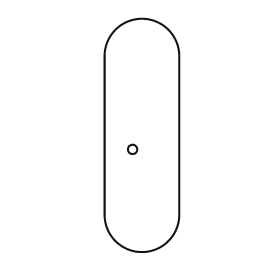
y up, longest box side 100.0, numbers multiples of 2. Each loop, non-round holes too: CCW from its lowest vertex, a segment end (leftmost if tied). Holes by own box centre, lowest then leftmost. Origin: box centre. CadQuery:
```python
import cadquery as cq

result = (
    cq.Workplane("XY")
    .moveTo(-16.0, -34.0)
    .threePointArc((0.0, -50.0), (16.0, -34.0))
    .lineTo(16.0, 34.0)
    .threePointArc((0.0, 50.0), (-16.0, 34.0))
    .close()
    .moveTo(-4.0, -6.0)
    .circle(2.0)
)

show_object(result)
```